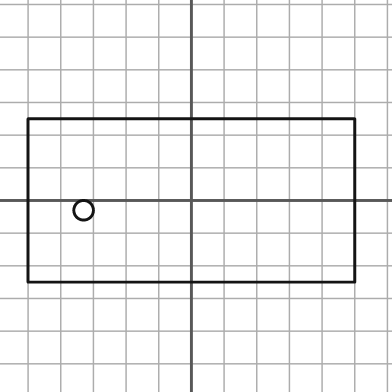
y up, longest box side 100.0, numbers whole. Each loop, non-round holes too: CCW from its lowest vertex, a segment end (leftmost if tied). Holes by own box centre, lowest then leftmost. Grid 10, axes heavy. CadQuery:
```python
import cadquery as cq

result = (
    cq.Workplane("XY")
    .moveTo(-50.0, -25.0)
    .lineTo(50.0, -25.0)
    .lineTo(50.0, 25.0)
    .lineTo(-50.0, 25.0)
    .close()
    .moveTo(-33.0, -3.0)
    .circle(3.0)
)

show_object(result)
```